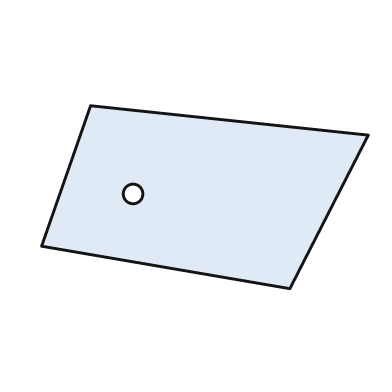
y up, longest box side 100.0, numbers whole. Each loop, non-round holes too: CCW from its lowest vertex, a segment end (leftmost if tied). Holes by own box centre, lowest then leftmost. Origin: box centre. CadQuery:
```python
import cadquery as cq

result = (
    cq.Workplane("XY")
    .moveTo(26.0, -28.0)
    .lineTo(50.0, 19.0)
    .lineTo(-35.0, 28.0)
    .lineTo(-50.0, -15.0)
    .close()
    .moveTo(-22.0, 1.0)
    .circle(3.0)
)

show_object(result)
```